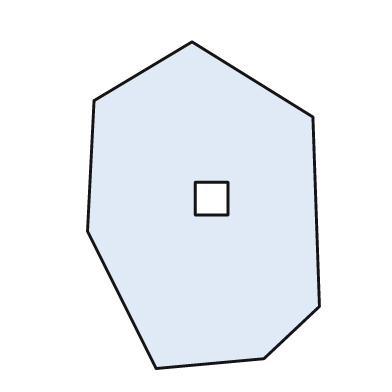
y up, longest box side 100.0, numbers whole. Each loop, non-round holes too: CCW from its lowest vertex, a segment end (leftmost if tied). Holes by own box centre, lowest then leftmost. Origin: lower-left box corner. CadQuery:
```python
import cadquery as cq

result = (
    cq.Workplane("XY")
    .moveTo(21.0, 0.0)
    .lineTo(54.0, 3.0)
    .lineTo(71.0, 19.0)
    .lineTo(69.0, 77.0)
    .lineTo(32.0, 100.0)
    .lineTo(2.0, 82.0)
    .lineTo(0.0, 42.0)
    .close()
    .moveTo(33.0, 47.0)
    .lineTo(43.0, 47.0)
    .lineTo(43.0, 57.0)
    .lineTo(33.0, 57.0)
    .close()
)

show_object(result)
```